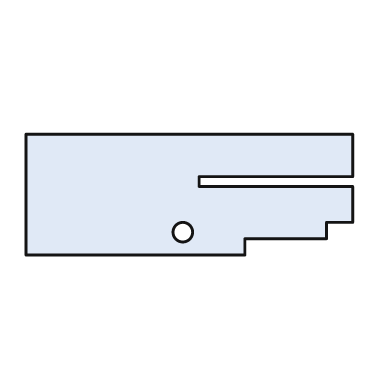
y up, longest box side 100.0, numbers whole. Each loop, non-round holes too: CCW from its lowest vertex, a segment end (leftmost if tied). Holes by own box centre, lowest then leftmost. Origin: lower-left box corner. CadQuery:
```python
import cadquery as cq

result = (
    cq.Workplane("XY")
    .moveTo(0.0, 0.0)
    .lineTo(67.0, 0.0)
    .lineTo(67.0, 5.0)
    .lineTo(92.0, 5.0)
    .lineTo(92.0, 10.0)
    .lineTo(100.0, 10.0)
    .lineTo(100.0, 21.0)
    .lineTo(53.0, 21.0)
    .lineTo(53.0, 24.0)
    .lineTo(100.0, 24.0)
    .lineTo(100.0, 37.0)
    .lineTo(0.0, 37.0)
    .close()
    .moveTo(48.0, 7.0)
    .circle(3.0)
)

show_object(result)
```